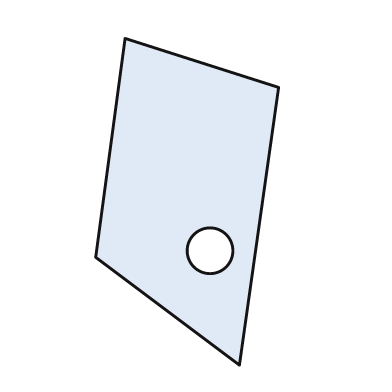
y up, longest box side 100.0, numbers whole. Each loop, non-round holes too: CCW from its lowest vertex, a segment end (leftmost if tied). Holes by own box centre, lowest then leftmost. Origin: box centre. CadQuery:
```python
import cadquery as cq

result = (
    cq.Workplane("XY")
    .moveTo(16.0, -50.0)
    .lineTo(28.0, 35.0)
    .lineTo(-19.0, 50.0)
    .lineTo(-28.0, -17.0)
    .close()
    .moveTo(7.0, -15.0)
    .circle(7.0)
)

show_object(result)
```